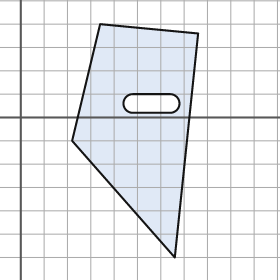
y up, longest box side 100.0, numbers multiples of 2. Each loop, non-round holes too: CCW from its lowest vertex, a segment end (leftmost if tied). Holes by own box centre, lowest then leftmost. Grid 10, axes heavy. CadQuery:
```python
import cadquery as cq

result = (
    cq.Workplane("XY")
    .moveTo(66.0, -60.0)
    .lineTo(76.0, 36.0)
    .lineTo(34.0, 40.0)
    .lineTo(22.0, -10.0)
    .close()
    .moveTo(48.0, 2.0)
    .lineTo(64.0, 2.0)
    .threePointArc((68.0, 6.0), (64.0, 10.0))
    .lineTo(48.0, 10.0)
    .threePointArc((44.0, 6.0), (48.0, 2.0))
    .close()
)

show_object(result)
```